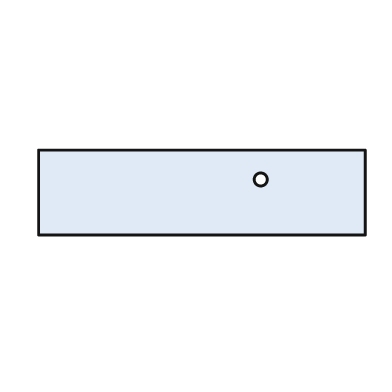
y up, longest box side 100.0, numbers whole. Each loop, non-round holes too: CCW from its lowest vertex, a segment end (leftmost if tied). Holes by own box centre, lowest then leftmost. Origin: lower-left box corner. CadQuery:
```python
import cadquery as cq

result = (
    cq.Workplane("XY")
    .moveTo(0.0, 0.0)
    .lineTo(100.0, 0.0)
    .lineTo(100.0, 26.0)
    .lineTo(0.0, 26.0)
    .close()
    .moveTo(68.0, 17.0)
    .circle(2.0)
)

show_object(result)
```